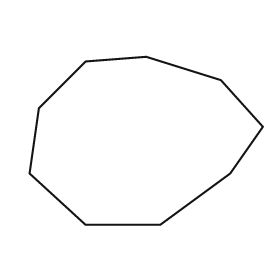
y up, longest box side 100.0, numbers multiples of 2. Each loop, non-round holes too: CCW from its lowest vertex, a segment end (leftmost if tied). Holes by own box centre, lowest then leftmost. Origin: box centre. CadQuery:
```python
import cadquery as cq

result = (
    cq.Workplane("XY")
    .moveTo(-26.0, -36.0)
    .lineTo(6.0, -36.0)
    .lineTo(36.0, -14.0)
    .lineTo(50.0, 6.0)
    .lineTo(32.0, 26.0)
    .lineTo(0.0, 36.0)
    .lineTo(-26.0, 34.0)
    .lineTo(-46.0, 14.0)
    .lineTo(-50.0, -14.0)
    .close()
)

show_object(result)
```